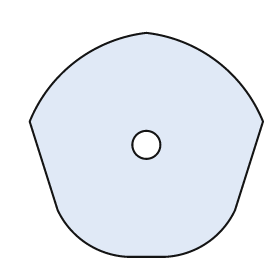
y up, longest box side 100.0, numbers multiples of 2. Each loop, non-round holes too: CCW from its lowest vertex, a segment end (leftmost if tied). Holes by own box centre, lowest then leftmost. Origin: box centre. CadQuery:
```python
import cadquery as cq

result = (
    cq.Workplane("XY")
    .moveTo(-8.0, -48.0)
    .lineTo(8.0, -48.0)
    .threePointArc((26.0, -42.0), (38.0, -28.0))
    .lineTo(50.0, 10.0)
    .threePointArc((30.0, 36.0), (0.0, 48.0))
    .threePointArc((-30.0, 36.0), (-50.0, 10.0))
    .lineTo(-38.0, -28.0)
    .threePointArc((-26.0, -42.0), (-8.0, -48.0))
    .close()
    .moveTo(0.0, 0.0)
    .circle(6.0)
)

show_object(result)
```